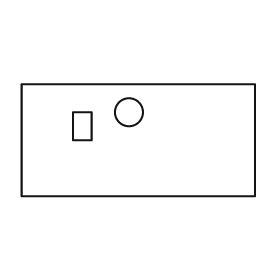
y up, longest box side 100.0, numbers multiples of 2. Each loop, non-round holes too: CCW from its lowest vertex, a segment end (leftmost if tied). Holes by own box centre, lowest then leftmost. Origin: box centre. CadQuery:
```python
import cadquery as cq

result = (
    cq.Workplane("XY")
    .moveTo(-50.0, -24.0)
    .lineTo(50.0, -24.0)
    .lineTo(50.0, 24.0)
    .lineTo(-50.0, 24.0)
    .close()
    .moveTo(-28.0, 0.0)
    .lineTo(-20.0, 0.0)
    .lineTo(-20.0, 12.0)
    .lineTo(-28.0, 12.0)
    .close()
    .moveTo(-4.0, 12.0)
    .circle(6.0)
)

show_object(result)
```